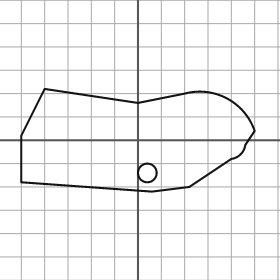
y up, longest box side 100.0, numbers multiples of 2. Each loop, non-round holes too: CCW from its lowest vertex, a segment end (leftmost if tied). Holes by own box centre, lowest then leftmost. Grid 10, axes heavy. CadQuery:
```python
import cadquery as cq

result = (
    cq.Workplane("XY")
    .moveTo(6.0, -22.0)
    .lineTo(22.0, -20.0)
    .lineTo(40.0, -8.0)
    .threePointArc((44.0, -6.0), (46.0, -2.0))
    .lineTo(50.0, 4.0)
    .threePointArc((38.0, 18.0), (20.0, 20.0))
    .lineTo(0.0, 16.0)
    .lineTo(-40.0, 22.0)
    .lineTo(-50.0, 2.0)
    .lineTo(-50.0, -18.0)
    .close()
    .moveTo(4.0, -14.0)
    .circle(4.0)
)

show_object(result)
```